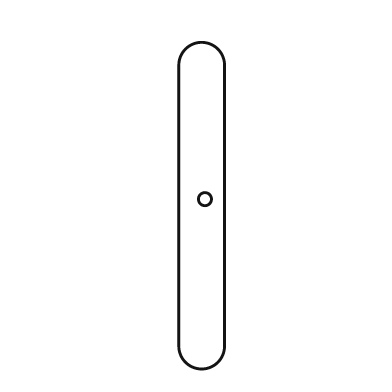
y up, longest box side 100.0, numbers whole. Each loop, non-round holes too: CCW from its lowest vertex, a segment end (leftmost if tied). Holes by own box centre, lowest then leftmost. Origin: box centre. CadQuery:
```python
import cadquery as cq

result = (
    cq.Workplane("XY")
    .moveTo(-7.0, -43.0)
    .threePointArc((0.0, -50.0), (7.0, -43.0))
    .lineTo(7.0, 43.0)
    .threePointArc((0.0, 50.0), (-7.0, 43.0))
    .close()
    .moveTo(1.0, 2.0)
    .circle(2.0)
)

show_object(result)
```